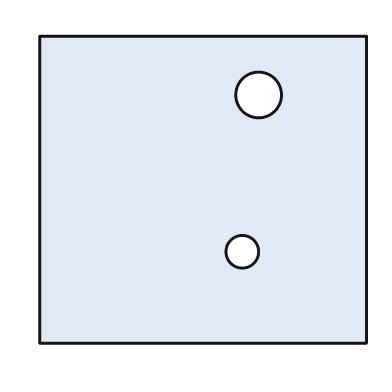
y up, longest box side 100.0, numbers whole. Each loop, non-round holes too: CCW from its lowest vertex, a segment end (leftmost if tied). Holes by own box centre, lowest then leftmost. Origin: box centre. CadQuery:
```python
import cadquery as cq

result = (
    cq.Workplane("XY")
    .moveTo(-50.0, -47.0)
    .lineTo(50.0, -47.0)
    .lineTo(50.0, 47.0)
    .lineTo(-50.0, 47.0)
    .close()
    .moveTo(12.0, -19.0)
    .circle(5.0)
    .moveTo(17.0, 29.0)
    .circle(7.0)
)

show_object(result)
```